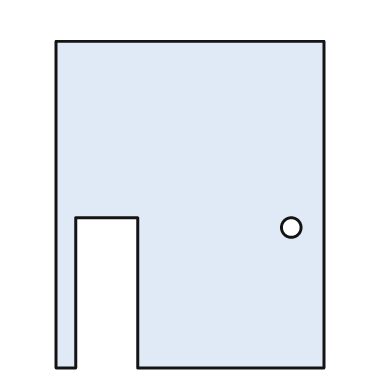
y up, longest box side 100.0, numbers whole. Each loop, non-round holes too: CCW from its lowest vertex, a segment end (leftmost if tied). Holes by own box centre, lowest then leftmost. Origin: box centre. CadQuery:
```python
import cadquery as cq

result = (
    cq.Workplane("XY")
    .moveTo(-41.0, -50.0)
    .lineTo(-35.0, -50.0)
    .lineTo(-35.0, -4.0)
    .lineTo(-16.0, -4.0)
    .lineTo(-16.0, -50.0)
    .lineTo(41.0, -50.0)
    .lineTo(41.0, 50.0)
    .lineTo(-41.0, 50.0)
    .close()
    .moveTo(31.0, -7.0)
    .circle(3.0)
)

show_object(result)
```